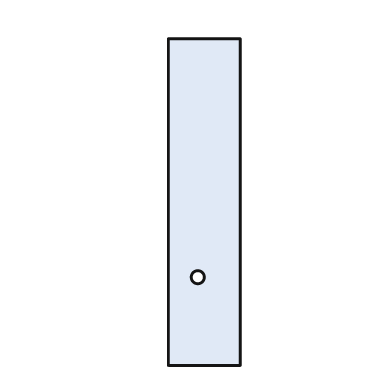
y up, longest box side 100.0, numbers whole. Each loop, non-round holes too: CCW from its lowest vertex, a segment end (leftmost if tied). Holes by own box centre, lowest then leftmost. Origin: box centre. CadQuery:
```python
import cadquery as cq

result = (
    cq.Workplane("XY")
    .moveTo(-11.0, -50.0)
    .lineTo(11.0, -50.0)
    .lineTo(11.0, 50.0)
    .lineTo(-11.0, 50.0)
    .close()
    .moveTo(-2.0, -23.0)
    .circle(2.0)
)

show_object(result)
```